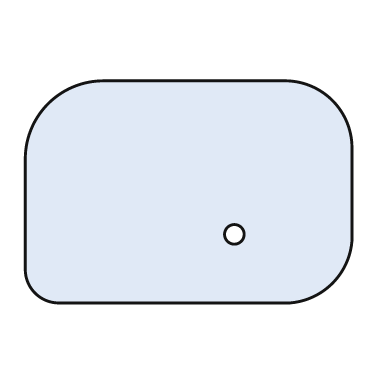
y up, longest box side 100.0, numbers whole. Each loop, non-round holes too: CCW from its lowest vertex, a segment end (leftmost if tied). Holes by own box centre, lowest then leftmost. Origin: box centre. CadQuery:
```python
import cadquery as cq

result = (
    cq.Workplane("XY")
    .moveTo(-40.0, -34.0)
    .lineTo(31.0, -34.0)
    .threePointArc((44.0, -28.0), (50.0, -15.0))
    .lineTo(50.0, 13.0)
    .threePointArc((44.0, 28.0), (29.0, 34.0))
    .lineTo(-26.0, 34.0)
    .threePointArc((-43.0, 27.0), (-50.0, 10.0))
    .lineTo(-50.0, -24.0)
    .threePointArc((-47.0, -31.0), (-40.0, -34.0))
    .close()
    .moveTo(14.0, -13.0)
    .circle(3.0)
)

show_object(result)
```